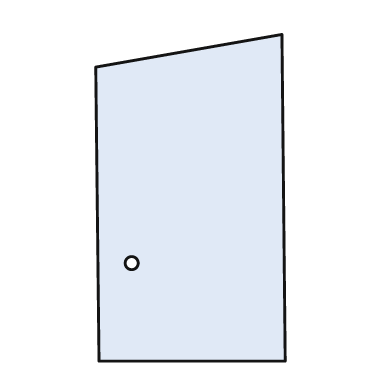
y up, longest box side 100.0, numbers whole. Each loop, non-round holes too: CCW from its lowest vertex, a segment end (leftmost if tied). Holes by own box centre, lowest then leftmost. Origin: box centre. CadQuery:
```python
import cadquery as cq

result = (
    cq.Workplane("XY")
    .moveTo(-28.0, -50.0)
    .lineTo(29.0, -50.0)
    .lineTo(28.0, 50.0)
    .lineTo(-29.0, 40.0)
    .close()
    .moveTo(-18.0, -20.0)
    .circle(2.0)
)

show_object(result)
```